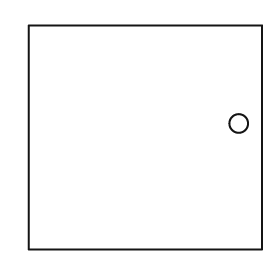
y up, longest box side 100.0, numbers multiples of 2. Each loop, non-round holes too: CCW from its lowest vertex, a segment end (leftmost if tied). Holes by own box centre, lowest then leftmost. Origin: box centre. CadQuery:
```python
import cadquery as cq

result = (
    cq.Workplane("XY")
    .moveTo(-50.0, -48.0)
    .lineTo(50.0, -48.0)
    .lineTo(50.0, 48.0)
    .lineTo(-50.0, 48.0)
    .close()
    .moveTo(40.0, 6.0)
    .circle(4.0)
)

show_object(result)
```